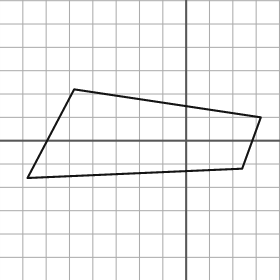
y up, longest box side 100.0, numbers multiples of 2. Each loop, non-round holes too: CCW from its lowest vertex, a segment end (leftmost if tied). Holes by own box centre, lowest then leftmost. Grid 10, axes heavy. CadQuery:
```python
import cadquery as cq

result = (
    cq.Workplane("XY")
    .moveTo(-68.0, -16.0)
    .lineTo(24.0, -12.0)
    .lineTo(32.0, 10.0)
    .lineTo(-48.0, 22.0)
    .close()
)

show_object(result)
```